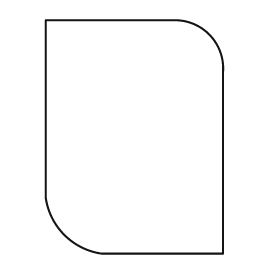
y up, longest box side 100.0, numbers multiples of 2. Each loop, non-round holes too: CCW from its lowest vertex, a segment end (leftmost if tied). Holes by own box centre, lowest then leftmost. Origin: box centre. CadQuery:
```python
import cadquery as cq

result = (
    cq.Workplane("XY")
    .moveTo(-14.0, -50.0)
    .lineTo(38.0, -50.0)
    .lineTo(38.0, 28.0)
    .threePointArc((32.0, 44.0), (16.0, 50.0))
    .lineTo(-38.0, 50.0)
    .lineTo(-38.0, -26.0)
    .threePointArc((-30.0, -42.0), (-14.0, -50.0))
    .close()
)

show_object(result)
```